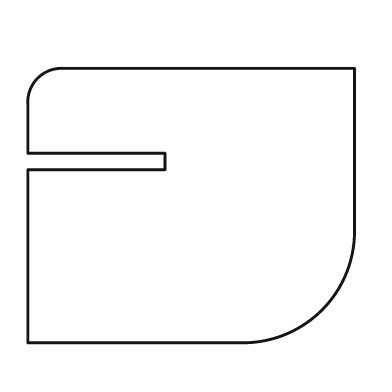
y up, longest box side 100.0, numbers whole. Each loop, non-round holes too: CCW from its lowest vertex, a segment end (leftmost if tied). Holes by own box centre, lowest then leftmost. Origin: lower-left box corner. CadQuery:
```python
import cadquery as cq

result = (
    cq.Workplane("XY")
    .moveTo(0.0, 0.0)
    .lineTo(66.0, 0.0)
    .threePointArc((90.0, 10.0), (100.0, 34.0))
    .lineTo(100.0, 84.0)
    .lineTo(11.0, 84.0)
    .threePointArc((3.0, 81.0), (0.0, 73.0))
    .lineTo(0.0, 58.0)
    .lineTo(42.0, 58.0)
    .lineTo(42.0, 53.0)
    .lineTo(0.0, 53.0)
    .close()
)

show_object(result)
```